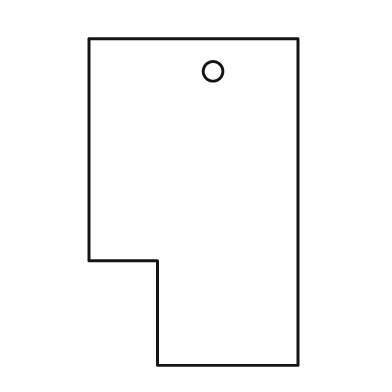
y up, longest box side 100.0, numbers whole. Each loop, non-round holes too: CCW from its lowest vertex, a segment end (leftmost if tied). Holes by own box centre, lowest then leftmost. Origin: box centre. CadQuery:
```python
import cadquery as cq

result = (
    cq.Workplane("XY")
    .moveTo(-11.0, -50.0)
    .lineTo(32.0, -50.0)
    .lineTo(32.0, 50.0)
    .lineTo(-32.0, 50.0)
    .lineTo(-32.0, -18.0)
    .lineTo(-11.0, -18.0)
    .close()
    .moveTo(6.0, 40.0)
    .circle(3.0)
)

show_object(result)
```